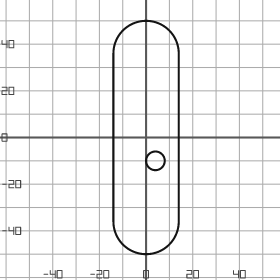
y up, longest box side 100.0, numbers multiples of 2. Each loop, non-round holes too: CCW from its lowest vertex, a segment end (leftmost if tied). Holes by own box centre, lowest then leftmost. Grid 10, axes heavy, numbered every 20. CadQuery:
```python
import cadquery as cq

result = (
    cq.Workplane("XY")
    .moveTo(-14.0, -36.0)
    .threePointArc((0.0, -50.0), (14.0, -36.0))
    .lineTo(14.0, 36.0)
    .threePointArc((0.0, 50.0), (-14.0, 36.0))
    .close()
    .moveTo(4.0, -10.0)
    .circle(4.0)
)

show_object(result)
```